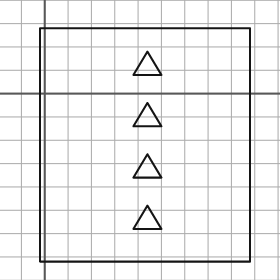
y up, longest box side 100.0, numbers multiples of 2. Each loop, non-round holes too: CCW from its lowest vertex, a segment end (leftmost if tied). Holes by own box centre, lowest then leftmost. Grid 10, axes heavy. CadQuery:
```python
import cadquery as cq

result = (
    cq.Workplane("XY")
    .moveTo(-2.0, -72.0)
    .lineTo(88.0, -72.0)
    .lineTo(88.0, 28.0)
    .lineTo(-2.0, 28.0)
    .close()
    .moveTo(38.0, -58.0)
    .lineTo(50.0, -58.0)
    .lineTo(44.0, -48.0)
    .close()
    .moveTo(38.0, -36.0)
    .lineTo(50.0, -36.0)
    .lineTo(44.0, -26.0)
    .close()
    .moveTo(38.0, -14.0)
    .lineTo(50.0, -14.0)
    .lineTo(44.0, -4.0)
    .close()
    .moveTo(38.0, 8.0)
    .lineTo(50.0, 8.0)
    .lineTo(44.0, 18.0)
    .close()
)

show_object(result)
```